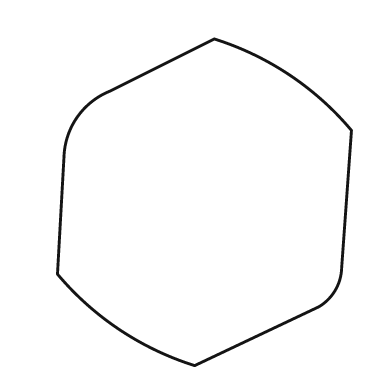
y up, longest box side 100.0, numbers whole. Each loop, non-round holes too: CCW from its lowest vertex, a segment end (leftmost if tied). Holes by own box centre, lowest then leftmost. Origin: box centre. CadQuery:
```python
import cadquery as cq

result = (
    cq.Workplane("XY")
    .moveTo(-3.0, -50.0)
    .lineTo(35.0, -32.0)
    .threePointArc((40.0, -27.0), (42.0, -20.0))
    .lineTo(45.0, 22.0)
    .threePointArc((26.0, 39.0), (3.0, 50.0))
    .lineTo(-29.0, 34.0)
    .threePointArc((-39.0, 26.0), (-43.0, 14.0))
    .lineTo(-45.0, -22.0)
    .threePointArc((-26.0, -39.0), (-3.0, -50.0))
    .close()
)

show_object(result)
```